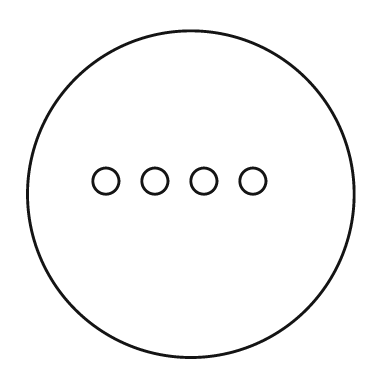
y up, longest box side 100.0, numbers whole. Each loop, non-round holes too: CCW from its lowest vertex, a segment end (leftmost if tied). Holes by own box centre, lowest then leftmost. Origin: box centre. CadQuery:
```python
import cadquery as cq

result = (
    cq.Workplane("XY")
    .moveTo(0.0, 0.0)
    .circle(50.0)
    .moveTo(-26.0, 4.0)
    .circle(4.0)
    .moveTo(-11.0, 4.0)
    .circle(4.0)
    .moveTo(4.0, 4.0)
    .circle(4.0)
    .moveTo(19.0, 4.0)
    .circle(4.0)
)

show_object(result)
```